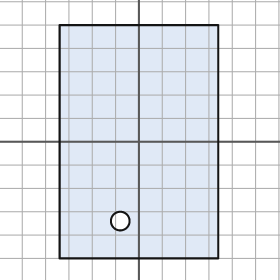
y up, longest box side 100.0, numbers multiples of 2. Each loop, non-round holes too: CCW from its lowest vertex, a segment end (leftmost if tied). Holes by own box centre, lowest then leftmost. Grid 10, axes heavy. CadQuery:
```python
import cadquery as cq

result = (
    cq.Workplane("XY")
    .moveTo(-34.0, -50.0)
    .lineTo(34.0, -50.0)
    .lineTo(34.0, 50.0)
    .lineTo(-34.0, 50.0)
    .close()
    .moveTo(-8.0, -34.0)
    .circle(4.0)
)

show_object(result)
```